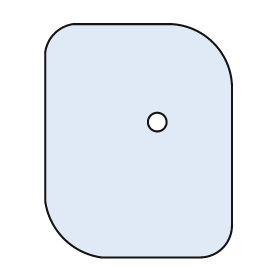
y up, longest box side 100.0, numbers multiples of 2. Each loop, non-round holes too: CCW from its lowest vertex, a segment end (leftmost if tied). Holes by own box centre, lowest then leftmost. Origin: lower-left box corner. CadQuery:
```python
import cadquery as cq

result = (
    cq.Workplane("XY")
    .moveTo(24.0, 0.0)
    .lineTo(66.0, 0.0)
    .threePointArc((76.0, 4.0), (80.0, 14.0))
    .lineTo(80.0, 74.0)
    .threePointArc((72.0, 92.0), (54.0, 100.0))
    .lineTo(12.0, 100.0)
    .threePointArc((4.0, 96.0), (0.0, 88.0))
    .lineTo(0.0, 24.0)
    .threePointArc((8.0, 8.0), (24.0, 0.0))
    .close()
    .moveTo(48.0, 58.0)
    .circle(4.0)
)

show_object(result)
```